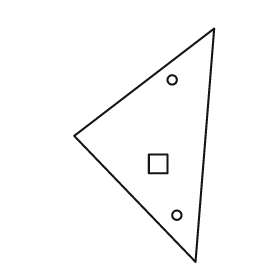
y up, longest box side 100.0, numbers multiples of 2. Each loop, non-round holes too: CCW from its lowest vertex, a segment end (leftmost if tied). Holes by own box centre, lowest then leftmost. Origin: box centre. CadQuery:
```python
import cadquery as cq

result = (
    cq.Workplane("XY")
    .moveTo(22.0, -50.0)
    .lineTo(30.0, 50.0)
    .lineTo(-30.0, 4.0)
    .close()
    .moveTo(14.0, -30.0)
    .circle(2.0)
    .moveTo(2.0, -12.0)
    .lineTo(10.0, -12.0)
    .lineTo(10.0, -4.0)
    .lineTo(2.0, -4.0)
    .close()
    .moveTo(12.0, 28.0)
    .circle(2.0)
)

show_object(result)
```